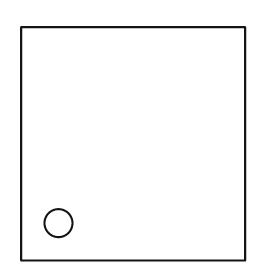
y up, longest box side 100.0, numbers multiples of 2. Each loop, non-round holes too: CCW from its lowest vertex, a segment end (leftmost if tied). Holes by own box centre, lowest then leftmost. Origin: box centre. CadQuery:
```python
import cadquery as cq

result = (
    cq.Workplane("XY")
    .moveTo(-48.0, -50.0)
    .lineTo(48.0, -50.0)
    .lineTo(48.0, 50.0)
    .lineTo(-48.0, 50.0)
    .close()
    .moveTo(-32.0, -34.0)
    .circle(6.0)
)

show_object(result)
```